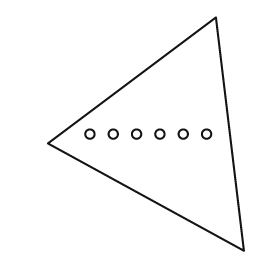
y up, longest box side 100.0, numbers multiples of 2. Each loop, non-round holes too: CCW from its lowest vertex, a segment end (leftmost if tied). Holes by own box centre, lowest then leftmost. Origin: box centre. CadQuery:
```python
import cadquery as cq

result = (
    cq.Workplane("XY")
    .moveTo(42.0, -50.0)
    .lineTo(30.0, 50.0)
    .lineTo(-42.0, -4.0)
    .close()
    .moveTo(-24.0, 0.0)
    .circle(2.0)
    .moveTo(-14.0, 0.0)
    .circle(2.0)
    .moveTo(-4.0, 0.0)
    .circle(2.0)
    .moveTo(6.0, 0.0)
    .circle(2.0)
    .moveTo(16.0, 0.0)
    .circle(2.0)
    .moveTo(26.0, 0.0)
    .circle(2.0)
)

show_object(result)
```